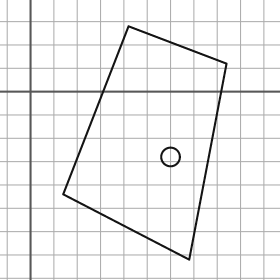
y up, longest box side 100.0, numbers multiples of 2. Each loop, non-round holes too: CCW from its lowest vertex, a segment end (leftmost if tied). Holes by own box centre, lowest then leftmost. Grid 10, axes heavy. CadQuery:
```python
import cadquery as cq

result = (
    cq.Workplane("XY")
    .moveTo(68.0, -72.0)
    .lineTo(84.0, 12.0)
    .lineTo(42.0, 28.0)
    .lineTo(14.0, -44.0)
    .close()
    .moveTo(60.0, -28.0)
    .circle(4.0)
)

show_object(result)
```